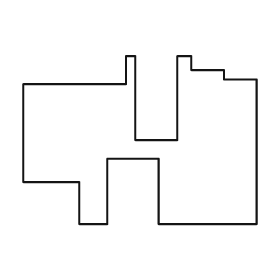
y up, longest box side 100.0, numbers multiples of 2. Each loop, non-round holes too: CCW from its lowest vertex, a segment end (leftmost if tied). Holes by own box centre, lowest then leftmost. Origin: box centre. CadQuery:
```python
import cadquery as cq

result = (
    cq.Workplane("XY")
    .moveTo(-26.0, -36.0)
    .lineTo(-14.0, -36.0)
    .lineTo(-14.0, -8.0)
    .lineTo(8.0, -8.0)
    .lineTo(8.0, -36.0)
    .lineTo(50.0, -36.0)
    .lineTo(50.0, 26.0)
    .lineTo(36.0, 26.0)
    .lineTo(36.0, 30.0)
    .lineTo(22.0, 30.0)
    .lineTo(22.0, 36.0)
    .lineTo(16.0, 36.0)
    .lineTo(16.0, 0.0)
    .lineTo(-2.0, 0.0)
    .lineTo(-2.0, 36.0)
    .lineTo(-6.0, 36.0)
    .lineTo(-6.0, 24.0)
    .lineTo(-50.0, 24.0)
    .lineTo(-50.0, -18.0)
    .lineTo(-26.0, -18.0)
    .close()
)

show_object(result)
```